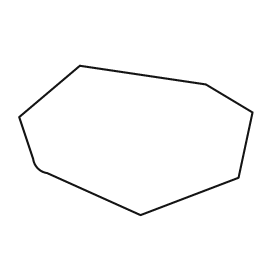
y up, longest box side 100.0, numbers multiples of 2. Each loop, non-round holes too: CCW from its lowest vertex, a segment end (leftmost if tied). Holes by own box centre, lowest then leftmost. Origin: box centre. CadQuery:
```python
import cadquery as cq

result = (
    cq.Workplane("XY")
    .moveTo(2.0, -32.0)
    .lineTo(44.0, -16.0)
    .lineTo(50.0, 12.0)
    .lineTo(30.0, 24.0)
    .lineTo(-24.0, 32.0)
    .lineTo(-50.0, 10.0)
    .lineTo(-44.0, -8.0)
    .threePointArc((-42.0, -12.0), (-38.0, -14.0))
    .close()
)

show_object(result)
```